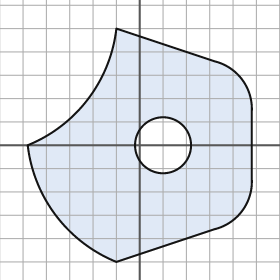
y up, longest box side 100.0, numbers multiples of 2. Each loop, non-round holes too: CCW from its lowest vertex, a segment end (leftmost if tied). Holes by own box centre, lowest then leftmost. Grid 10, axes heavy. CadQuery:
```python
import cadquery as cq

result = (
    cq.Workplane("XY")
    .moveTo(-10.0, -50.0)
    .lineTo(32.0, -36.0)
    .threePointArc((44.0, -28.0), (48.0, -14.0))
    .lineTo(48.0, 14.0)
    .threePointArc((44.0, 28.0), (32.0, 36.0))
    .lineTo(-10.0, 50.0)
    .threePointArc((-22.0, 20.0), (-48.0, 0.0))
    .threePointArc((-36.0, -30.0), (-10.0, -50.0))
    .close()
    .moveTo(10.0, 0.0)
    .circle(12.0)
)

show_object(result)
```